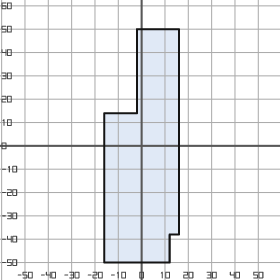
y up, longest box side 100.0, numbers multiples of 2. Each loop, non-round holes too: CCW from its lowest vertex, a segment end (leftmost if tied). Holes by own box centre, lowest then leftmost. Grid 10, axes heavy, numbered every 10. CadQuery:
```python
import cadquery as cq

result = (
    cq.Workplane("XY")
    .moveTo(-16.0, -50.0)
    .lineTo(12.0, -50.0)
    .lineTo(12.0, -38.0)
    .lineTo(16.0, -38.0)
    .lineTo(16.0, 50.0)
    .lineTo(-2.0, 50.0)
    .lineTo(-2.0, 14.0)
    .lineTo(-16.0, 14.0)
    .close()
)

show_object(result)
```